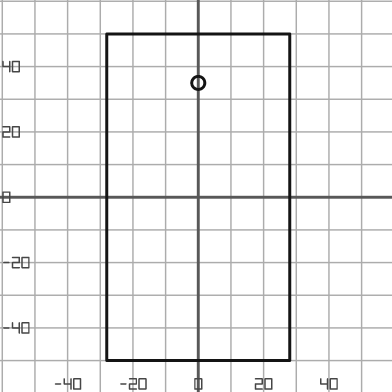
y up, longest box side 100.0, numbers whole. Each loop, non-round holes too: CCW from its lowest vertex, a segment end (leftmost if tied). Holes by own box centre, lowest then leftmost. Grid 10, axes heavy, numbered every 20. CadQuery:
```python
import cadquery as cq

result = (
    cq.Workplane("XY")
    .moveTo(-28.0, -50.0)
    .lineTo(28.0, -50.0)
    .lineTo(28.0, 50.0)
    .lineTo(-28.0, 50.0)
    .close()
    .moveTo(0.0, 35.0)
    .circle(2.0)
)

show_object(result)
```